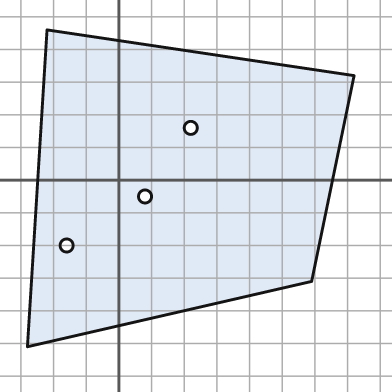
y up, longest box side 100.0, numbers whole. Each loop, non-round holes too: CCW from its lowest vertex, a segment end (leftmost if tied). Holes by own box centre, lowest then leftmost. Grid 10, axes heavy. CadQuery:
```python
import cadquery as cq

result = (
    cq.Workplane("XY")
    .moveTo(-28.0, -51.0)
    .lineTo(59.0, -31.0)
    .lineTo(72.0, 32.0)
    .lineTo(-22.0, 46.0)
    .close()
    .moveTo(-16.0, -20.0)
    .circle(2.0)
    .moveTo(8.0, -5.0)
    .circle(2.0)
    .moveTo(22.0, 16.0)
    .circle(2.0)
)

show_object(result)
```